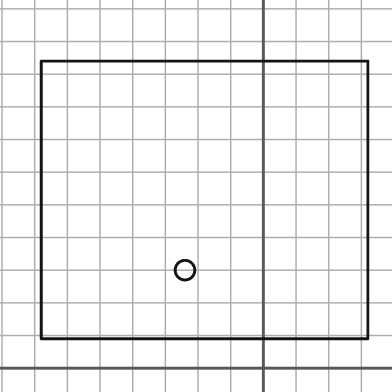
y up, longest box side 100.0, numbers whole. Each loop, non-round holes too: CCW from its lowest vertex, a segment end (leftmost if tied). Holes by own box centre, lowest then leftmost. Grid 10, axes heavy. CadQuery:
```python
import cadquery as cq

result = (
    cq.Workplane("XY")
    .moveTo(-68.0, 9.0)
    .lineTo(32.0, 9.0)
    .lineTo(32.0, 94.0)
    .lineTo(-68.0, 94.0)
    .close()
    .moveTo(-24.0, 30.0)
    .circle(3.0)
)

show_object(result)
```